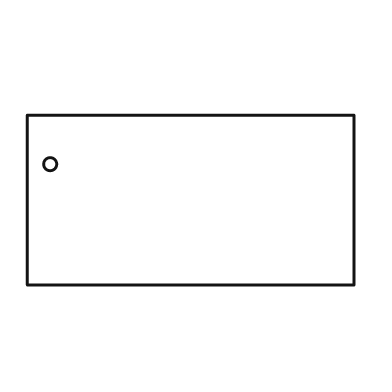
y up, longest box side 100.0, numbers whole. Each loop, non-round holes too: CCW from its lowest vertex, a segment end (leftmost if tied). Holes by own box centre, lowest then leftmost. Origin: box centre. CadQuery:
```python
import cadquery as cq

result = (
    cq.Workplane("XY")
    .moveTo(-50.0, -26.0)
    .lineTo(50.0, -26.0)
    .lineTo(50.0, 26.0)
    .lineTo(-50.0, 26.0)
    .close()
    .moveTo(-43.0, 11.0)
    .circle(2.0)
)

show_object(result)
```